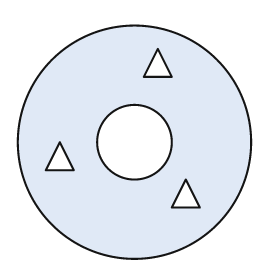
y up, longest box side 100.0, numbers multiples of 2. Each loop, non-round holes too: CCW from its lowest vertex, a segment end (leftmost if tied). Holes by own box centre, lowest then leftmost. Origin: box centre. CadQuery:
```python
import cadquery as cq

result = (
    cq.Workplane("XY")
    .moveTo(0.0, 0.0)
    .circle(50.0)
    .moveTo(16.0, -28.0)
    .lineTo(28.0, -28.0)
    .lineTo(22.0, -16.0)
    .close()
    .moveTo(-38.0, -12.0)
    .lineTo(-26.0, -12.0)
    .lineTo(-32.0, 0.0)
    .close()
    .moveTo(0.0, 0.0)
    .circle(16.0)
    .moveTo(4.0, 28.0)
    .lineTo(16.0, 28.0)
    .lineTo(10.0, 40.0)
    .close()
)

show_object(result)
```